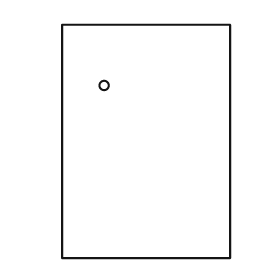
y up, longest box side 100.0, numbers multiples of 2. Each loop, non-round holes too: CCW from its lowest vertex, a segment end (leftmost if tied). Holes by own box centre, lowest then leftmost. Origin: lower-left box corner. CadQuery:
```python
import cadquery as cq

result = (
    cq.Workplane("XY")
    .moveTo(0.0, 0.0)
    .lineTo(72.0, 0.0)
    .lineTo(72.0, 100.0)
    .lineTo(0.0, 100.0)
    .close()
    .moveTo(18.0, 74.0)
    .circle(2.0)
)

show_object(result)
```